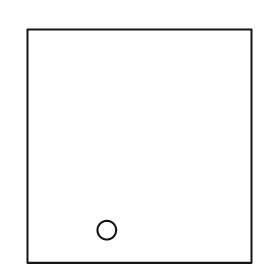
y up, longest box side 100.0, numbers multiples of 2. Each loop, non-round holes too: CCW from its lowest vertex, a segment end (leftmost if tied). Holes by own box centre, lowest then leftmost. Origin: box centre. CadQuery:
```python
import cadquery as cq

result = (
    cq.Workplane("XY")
    .moveTo(-48.0, -50.0)
    .lineTo(48.0, -50.0)
    .lineTo(48.0, 50.0)
    .lineTo(-48.0, 50.0)
    .close()
    .moveTo(-14.0, -36.0)
    .circle(4.0)
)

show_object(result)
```